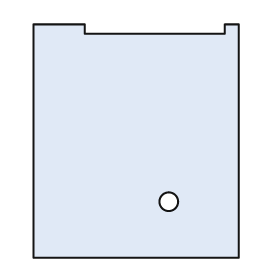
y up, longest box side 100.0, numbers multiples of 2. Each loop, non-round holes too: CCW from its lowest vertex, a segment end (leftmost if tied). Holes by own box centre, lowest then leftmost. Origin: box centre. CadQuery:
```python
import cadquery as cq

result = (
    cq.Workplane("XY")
    .moveTo(-44.0, -50.0)
    .lineTo(44.0, -50.0)
    .lineTo(44.0, 50.0)
    .lineTo(38.0, 50.0)
    .lineTo(38.0, 46.0)
    .lineTo(-22.0, 46.0)
    .lineTo(-22.0, 50.0)
    .lineTo(-44.0, 50.0)
    .close()
    .moveTo(14.0, -26.0)
    .circle(4.0)
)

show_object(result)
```